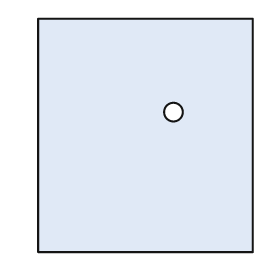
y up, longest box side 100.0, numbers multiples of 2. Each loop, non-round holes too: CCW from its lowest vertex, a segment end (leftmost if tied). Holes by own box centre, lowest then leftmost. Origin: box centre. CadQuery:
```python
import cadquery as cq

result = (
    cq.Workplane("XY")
    .moveTo(-46.0, -50.0)
    .lineTo(46.0, -50.0)
    .lineTo(46.0, 50.0)
    .lineTo(-46.0, 50.0)
    .close()
    .moveTo(12.0, 10.0)
    .circle(4.0)
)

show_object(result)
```